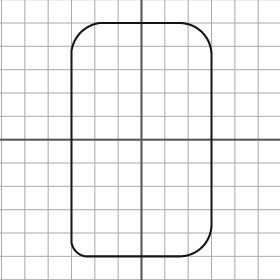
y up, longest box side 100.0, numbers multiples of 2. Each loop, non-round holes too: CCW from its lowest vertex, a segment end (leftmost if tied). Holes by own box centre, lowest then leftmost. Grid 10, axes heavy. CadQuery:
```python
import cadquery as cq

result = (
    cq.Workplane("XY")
    .moveTo(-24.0, -50.0)
    .lineTo(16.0, -50.0)
    .threePointArc((26.0, -46.0), (30.0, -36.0))
    .lineTo(30.0, 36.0)
    .threePointArc((26.0, 46.0), (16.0, 50.0))
    .lineTo(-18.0, 50.0)
    .threePointArc((-26.0, 46.0), (-30.0, 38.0))
    .lineTo(-30.0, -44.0)
    .threePointArc((-28.0, -48.0), (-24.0, -50.0))
    .close()
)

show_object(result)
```